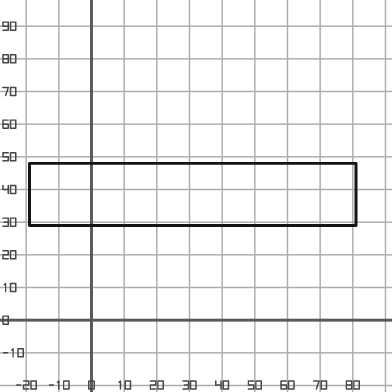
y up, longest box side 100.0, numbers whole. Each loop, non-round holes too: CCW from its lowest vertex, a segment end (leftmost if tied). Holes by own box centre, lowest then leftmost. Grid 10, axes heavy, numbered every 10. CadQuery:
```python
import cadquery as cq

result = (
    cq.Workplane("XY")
    .moveTo(-19.0, 29.0)
    .lineTo(81.0, 29.0)
    .lineTo(81.0, 48.0)
    .lineTo(-19.0, 48.0)
    .close()
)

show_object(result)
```